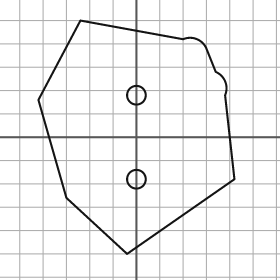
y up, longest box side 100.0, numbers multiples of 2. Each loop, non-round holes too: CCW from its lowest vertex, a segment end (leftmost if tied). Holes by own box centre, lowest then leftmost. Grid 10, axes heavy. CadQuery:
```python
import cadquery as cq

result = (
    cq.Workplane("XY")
    .moveTo(-4.0, -50.0)
    .lineTo(42.0, -18.0)
    .lineTo(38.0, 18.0)
    .threePointArc((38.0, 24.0), (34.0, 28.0))
    .lineTo(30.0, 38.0)
    .threePointArc((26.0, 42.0), (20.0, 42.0))
    .lineTo(-24.0, 50.0)
    .lineTo(-42.0, 16.0)
    .lineTo(-30.0, -26.0)
    .close()
    .moveTo(0.0, -18.0)
    .circle(4.0)
    .moveTo(0.0, 18.0)
    .circle(4.0)
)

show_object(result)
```